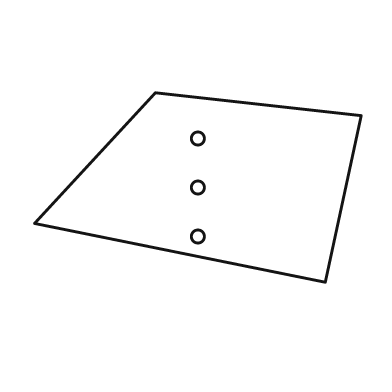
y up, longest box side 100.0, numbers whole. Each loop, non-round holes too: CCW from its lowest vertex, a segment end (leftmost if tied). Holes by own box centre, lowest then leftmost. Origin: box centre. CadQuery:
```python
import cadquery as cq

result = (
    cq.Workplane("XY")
    .moveTo(39.0, -29.0)
    .lineTo(50.0, 22.0)
    .lineTo(-13.0, 29.0)
    .lineTo(-50.0, -11.0)
    .close()
    .moveTo(0.0, -15.0)
    .circle(2.0)
    .moveTo(0.0, 0.0)
    .circle(2.0)
    .moveTo(0.0, 15.0)
    .circle(2.0)
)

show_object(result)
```